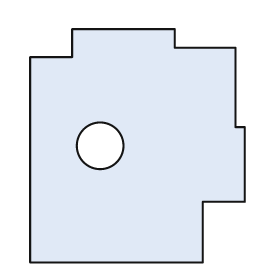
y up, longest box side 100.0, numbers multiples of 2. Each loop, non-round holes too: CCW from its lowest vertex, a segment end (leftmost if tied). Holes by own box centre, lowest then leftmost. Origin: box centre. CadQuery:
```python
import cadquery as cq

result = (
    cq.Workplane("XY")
    .moveTo(-46.0, -50.0)
    .lineTo(28.0, -50.0)
    .lineTo(28.0, -24.0)
    .lineTo(46.0, -24.0)
    .lineTo(46.0, 8.0)
    .lineTo(42.0, 8.0)
    .lineTo(42.0, 42.0)
    .lineTo(16.0, 42.0)
    .lineTo(16.0, 50.0)
    .lineTo(-28.0, 50.0)
    .lineTo(-28.0, 38.0)
    .lineTo(-46.0, 38.0)
    .close()
    .moveTo(-16.0, 0.0)
    .circle(10.0)
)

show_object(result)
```